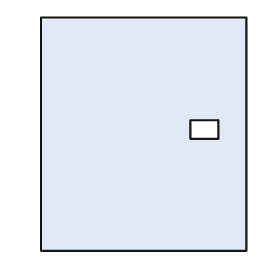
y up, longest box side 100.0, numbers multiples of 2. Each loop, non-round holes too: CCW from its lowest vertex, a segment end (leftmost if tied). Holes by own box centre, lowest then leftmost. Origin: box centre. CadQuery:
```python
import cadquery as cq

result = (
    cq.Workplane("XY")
    .moveTo(-44.0, -50.0)
    .lineTo(44.0, -50.0)
    .lineTo(44.0, 50.0)
    .lineTo(-44.0, 50.0)
    .close()
    .moveTo(20.0, -2.0)
    .lineTo(32.0, -2.0)
    .lineTo(32.0, 6.0)
    .lineTo(20.0, 6.0)
    .close()
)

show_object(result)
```